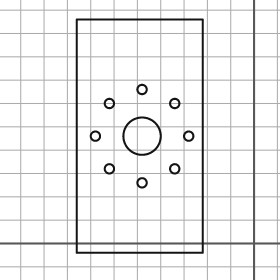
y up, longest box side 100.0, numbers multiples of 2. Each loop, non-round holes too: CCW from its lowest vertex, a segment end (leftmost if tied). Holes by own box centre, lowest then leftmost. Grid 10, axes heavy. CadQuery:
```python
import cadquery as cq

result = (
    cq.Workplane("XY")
    .moveTo(-76.0, -4.0)
    .lineTo(-22.0, -4.0)
    .lineTo(-22.0, 96.0)
    .lineTo(-76.0, 96.0)
    .close()
    .moveTo(-48.0, 26.0)
    .circle(2.0)
    .moveTo(-62.0, 32.0)
    .circle(2.0)
    .moveTo(-34.0, 32.0)
    .circle(2.0)
    .moveTo(-68.0, 46.0)
    .circle(2.0)
    .moveTo(-48.0, 46.0)
    .circle(8.0)
    .moveTo(-28.0, 46.0)
    .circle(2.0)
    .moveTo(-62.0, 60.0)
    .circle(2.0)
    .moveTo(-34.0, 60.0)
    .circle(2.0)
    .moveTo(-48.0, 66.0)
    .circle(2.0)
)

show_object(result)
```